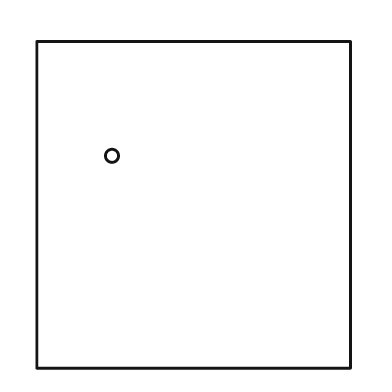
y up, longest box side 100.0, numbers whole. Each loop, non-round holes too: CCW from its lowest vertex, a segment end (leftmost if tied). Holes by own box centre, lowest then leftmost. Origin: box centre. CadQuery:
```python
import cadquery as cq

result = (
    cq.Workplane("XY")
    .moveTo(-48.0, -50.0)
    .lineTo(48.0, -50.0)
    .lineTo(48.0, 50.0)
    .lineTo(-48.0, 50.0)
    .close()
    .moveTo(-25.0, 15.0)
    .circle(2.0)
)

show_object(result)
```